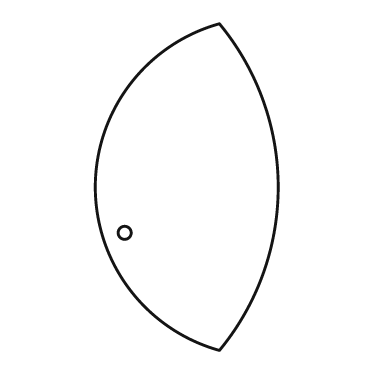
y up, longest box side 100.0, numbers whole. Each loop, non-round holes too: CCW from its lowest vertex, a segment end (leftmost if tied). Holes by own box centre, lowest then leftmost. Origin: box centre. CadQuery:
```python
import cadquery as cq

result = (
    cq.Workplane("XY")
    .moveTo(10.0, -50.0)
    .threePointArc((28.0, 0.0), (10.0, 50.0))
    .threePointArc((-28.0, 0.0), (10.0, -50.0))
    .close()
    .moveTo(-19.0, -14.0)
    .circle(2.0)
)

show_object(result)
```